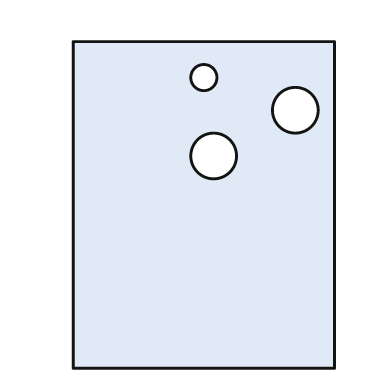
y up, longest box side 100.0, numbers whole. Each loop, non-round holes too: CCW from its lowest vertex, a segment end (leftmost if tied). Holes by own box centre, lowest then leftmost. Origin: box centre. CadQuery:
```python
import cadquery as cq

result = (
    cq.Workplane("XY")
    .moveTo(-40.0, -50.0)
    .lineTo(40.0, -50.0)
    .lineTo(40.0, 50.0)
    .lineTo(-40.0, 50.0)
    .close()
    .moveTo(3.0, 15.0)
    .circle(7.0)
    .moveTo(28.0, 29.0)
    .circle(7.0)
    .moveTo(0.0, 39.0)
    .circle(4.0)
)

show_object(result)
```